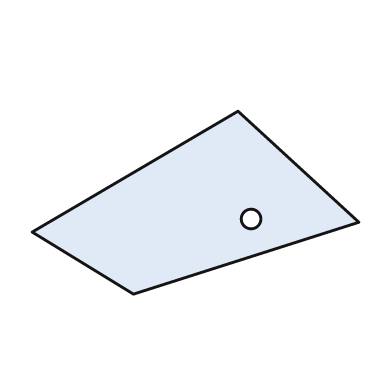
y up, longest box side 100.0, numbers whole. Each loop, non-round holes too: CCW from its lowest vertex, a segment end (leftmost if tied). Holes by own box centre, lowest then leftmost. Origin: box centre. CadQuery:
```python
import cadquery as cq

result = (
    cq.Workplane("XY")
    .moveTo(-19.0, -28.0)
    .lineTo(50.0, -6.0)
    .lineTo(13.0, 28.0)
    .lineTo(-50.0, -9.0)
    .close()
    .moveTo(17.0, -5.0)
    .circle(3.0)
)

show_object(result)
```